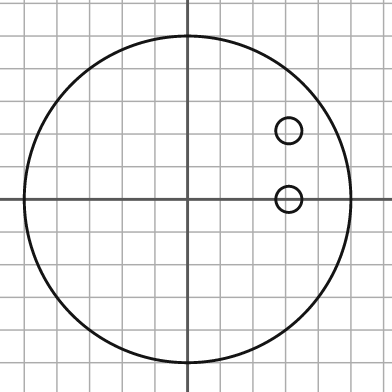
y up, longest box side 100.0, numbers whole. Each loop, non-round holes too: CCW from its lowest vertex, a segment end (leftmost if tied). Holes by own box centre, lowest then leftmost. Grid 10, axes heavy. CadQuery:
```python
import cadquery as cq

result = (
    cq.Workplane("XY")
    .moveTo(0.0, 0.0)
    .circle(50.0)
    .moveTo(31.0, 0.0)
    .circle(4.0)
    .moveTo(31.0, 21.0)
    .circle(4.0)
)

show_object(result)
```